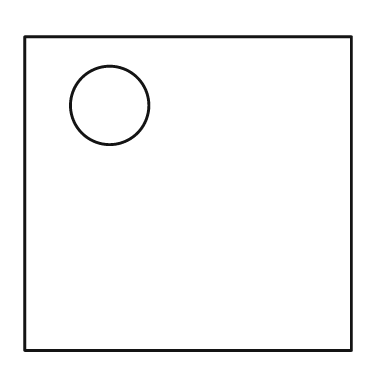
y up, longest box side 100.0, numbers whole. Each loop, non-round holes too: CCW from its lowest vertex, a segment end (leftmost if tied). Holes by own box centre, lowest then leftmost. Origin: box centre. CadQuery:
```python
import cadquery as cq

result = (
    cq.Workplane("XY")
    .moveTo(-50.0, -48.0)
    .lineTo(50.0, -48.0)
    .lineTo(50.0, 48.0)
    .lineTo(-50.0, 48.0)
    .close()
    .moveTo(-24.0, 27.0)
    .circle(12.0)
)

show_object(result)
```